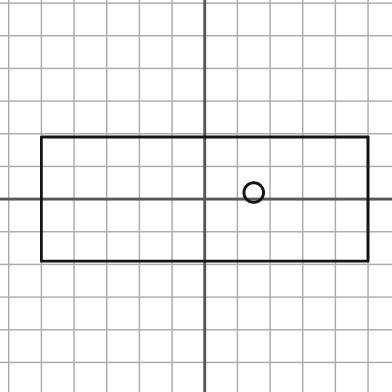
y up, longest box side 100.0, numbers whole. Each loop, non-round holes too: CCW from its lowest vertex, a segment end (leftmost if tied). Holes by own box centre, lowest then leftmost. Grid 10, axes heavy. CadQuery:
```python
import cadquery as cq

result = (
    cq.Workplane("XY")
    .moveTo(-50.0, -19.0)
    .lineTo(50.0, -19.0)
    .lineTo(50.0, 19.0)
    .lineTo(-50.0, 19.0)
    .close()
    .moveTo(15.0, 2.0)
    .circle(3.0)
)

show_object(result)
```